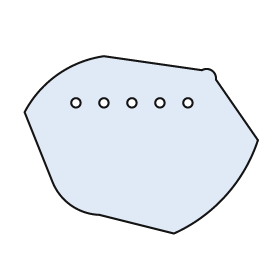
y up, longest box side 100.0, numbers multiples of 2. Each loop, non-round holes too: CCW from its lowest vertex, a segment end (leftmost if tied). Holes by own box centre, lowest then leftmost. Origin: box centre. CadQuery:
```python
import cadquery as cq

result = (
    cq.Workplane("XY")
    .moveTo(14.0, -38.0)
    .threePointArc((36.0, -22.0), (50.0, 2.0))
    .lineTo(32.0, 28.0)
    .threePointArc((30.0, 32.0), (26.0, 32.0))
    .lineTo(-16.0, 38.0)
    .threePointArc((-36.0, 30.0), (-50.0, 14.0))
    .lineTo(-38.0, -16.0)
    .threePointArc((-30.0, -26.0), (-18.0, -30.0))
    .close()
    .moveTo(-28.0, 18.0)
    .circle(2.0)
    .moveTo(-16.0, 18.0)
    .circle(2.0)
    .moveTo(-4.0, 18.0)
    .circle(2.0)
    .moveTo(8.0, 18.0)
    .circle(2.0)
    .moveTo(20.0, 18.0)
    .circle(2.0)
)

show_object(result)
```